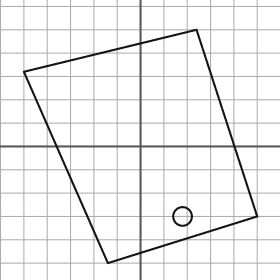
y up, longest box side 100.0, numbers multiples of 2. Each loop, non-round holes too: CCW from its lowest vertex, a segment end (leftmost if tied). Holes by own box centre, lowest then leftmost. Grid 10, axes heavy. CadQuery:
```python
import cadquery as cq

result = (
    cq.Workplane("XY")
    .moveTo(-14.0, -50.0)
    .lineTo(50.0, -30.0)
    .lineTo(24.0, 50.0)
    .lineTo(-50.0, 32.0)
    .close()
    .moveTo(18.0, -30.0)
    .circle(4.0)
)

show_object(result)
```